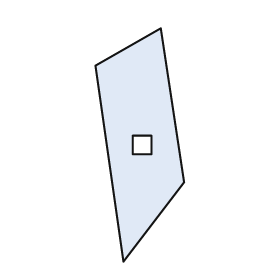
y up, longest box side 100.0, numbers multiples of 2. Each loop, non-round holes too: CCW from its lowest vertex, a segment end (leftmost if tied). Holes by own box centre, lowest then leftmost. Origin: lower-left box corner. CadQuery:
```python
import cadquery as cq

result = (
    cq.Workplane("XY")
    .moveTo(12.0, 0.0)
    .lineTo(38.0, 34.0)
    .lineTo(28.0, 100.0)
    .lineTo(0.0, 84.0)
    .close()
    .moveTo(16.0, 46.0)
    .lineTo(24.0, 46.0)
    .lineTo(24.0, 54.0)
    .lineTo(16.0, 54.0)
    .close()
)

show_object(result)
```